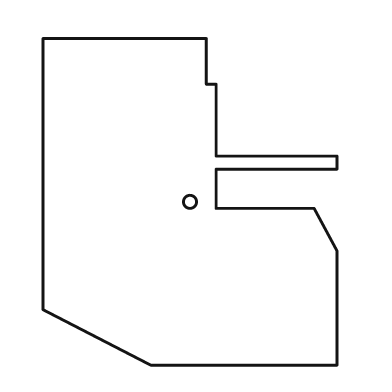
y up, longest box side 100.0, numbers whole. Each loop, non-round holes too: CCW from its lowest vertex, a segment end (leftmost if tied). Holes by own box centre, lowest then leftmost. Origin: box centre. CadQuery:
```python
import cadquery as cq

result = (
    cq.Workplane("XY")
    .moveTo(-12.0, -50.0)
    .lineTo(45.0, -50.0)
    .lineTo(45.0, -15.0)
    .lineTo(38.0, -2.0)
    .lineTo(8.0, -2.0)
    .lineTo(8.0, 10.0)
    .lineTo(45.0, 10.0)
    .lineTo(45.0, 14.0)
    .lineTo(8.0, 14.0)
    .lineTo(8.0, 36.0)
    .lineTo(5.0, 36.0)
    .lineTo(5.0, 50.0)
    .lineTo(-45.0, 50.0)
    .lineTo(-45.0, -33.0)
    .close()
    .moveTo(0.0, 0.0)
    .circle(2.0)
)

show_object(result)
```